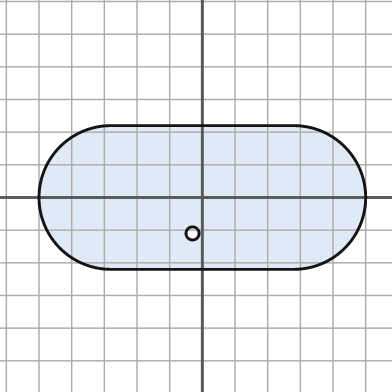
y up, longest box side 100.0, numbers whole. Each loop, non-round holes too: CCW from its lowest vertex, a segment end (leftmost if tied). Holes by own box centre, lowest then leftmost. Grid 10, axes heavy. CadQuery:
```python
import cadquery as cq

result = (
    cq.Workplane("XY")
    .moveTo(-28.0, -22.0)
    .lineTo(28.0, -22.0)
    .threePointArc((50.0, 0.0), (28.0, 22.0))
    .lineTo(-28.0, 22.0)
    .threePointArc((-50.0, 0.0), (-28.0, -22.0))
    .close()
    .moveTo(-3.0, -11.0)
    .circle(2.0)
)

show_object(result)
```